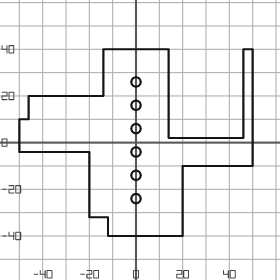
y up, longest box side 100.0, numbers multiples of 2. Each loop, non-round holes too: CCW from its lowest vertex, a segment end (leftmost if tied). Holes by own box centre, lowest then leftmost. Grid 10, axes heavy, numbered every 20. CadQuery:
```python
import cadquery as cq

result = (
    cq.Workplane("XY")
    .moveTo(-12.0, -40.0)
    .lineTo(20.0, -40.0)
    .lineTo(20.0, -10.0)
    .lineTo(50.0, -10.0)
    .lineTo(50.0, 40.0)
    .lineTo(46.0, 40.0)
    .lineTo(46.0, 2.0)
    .lineTo(14.0, 2.0)
    .lineTo(14.0, 40.0)
    .lineTo(-14.0, 40.0)
    .lineTo(-14.0, 20.0)
    .lineTo(-46.0, 20.0)
    .lineTo(-46.0, 10.0)
    .lineTo(-50.0, 10.0)
    .lineTo(-50.0, -4.0)
    .lineTo(-20.0, -4.0)
    .lineTo(-20.0, -32.0)
    .lineTo(-12.0, -32.0)
    .close()
    .moveTo(0.0, -24.0)
    .circle(2.0)
    .moveTo(0.0, -14.0)
    .circle(2.0)
    .moveTo(0.0, -4.0)
    .circle(2.0)
    .moveTo(0.0, 6.0)
    .circle(2.0)
    .moveTo(0.0, 16.0)
    .circle(2.0)
    .moveTo(0.0, 26.0)
    .circle(2.0)
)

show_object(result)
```